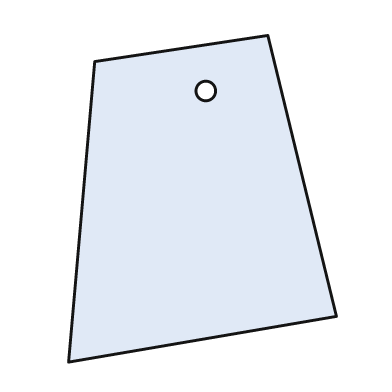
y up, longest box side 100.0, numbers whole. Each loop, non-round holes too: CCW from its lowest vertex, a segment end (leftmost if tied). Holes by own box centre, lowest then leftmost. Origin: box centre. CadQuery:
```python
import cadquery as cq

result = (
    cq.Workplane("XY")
    .moveTo(-41.0, -50.0)
    .lineTo(41.0, -36.0)
    .lineTo(20.0, 50.0)
    .lineTo(-33.0, 42.0)
    .close()
    .moveTo(1.0, 33.0)
    .circle(3.0)
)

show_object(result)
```